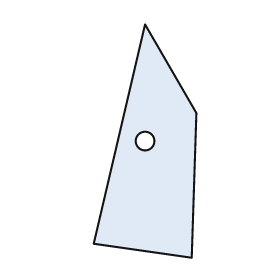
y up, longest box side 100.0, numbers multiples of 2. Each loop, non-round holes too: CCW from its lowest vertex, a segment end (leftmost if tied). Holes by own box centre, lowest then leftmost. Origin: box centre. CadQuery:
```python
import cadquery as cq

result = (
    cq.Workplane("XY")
    .moveTo(20.0, -50.0)
    .lineTo(22.0, 12.0)
    .lineTo(0.0, 50.0)
    .lineTo(-22.0, -44.0)
    .close()
    .moveTo(0.0, 0.0)
    .circle(4.0)
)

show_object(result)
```